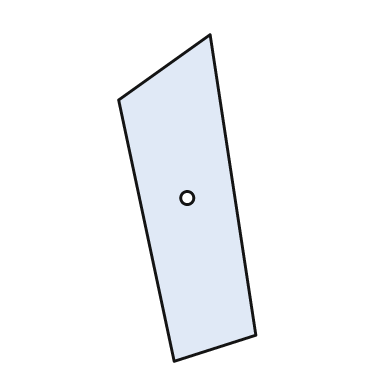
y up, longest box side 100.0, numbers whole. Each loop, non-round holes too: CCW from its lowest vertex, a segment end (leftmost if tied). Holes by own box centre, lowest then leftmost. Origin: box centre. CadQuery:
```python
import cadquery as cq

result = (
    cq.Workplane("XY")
    .moveTo(-4.0, -50.0)
    .lineTo(21.0, -42.0)
    .lineTo(7.0, 50.0)
    .lineTo(-21.0, 30.0)
    .close()
    .moveTo(0.0, 0.0)
    .circle(2.0)
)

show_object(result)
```